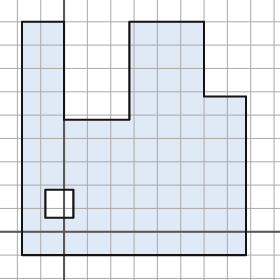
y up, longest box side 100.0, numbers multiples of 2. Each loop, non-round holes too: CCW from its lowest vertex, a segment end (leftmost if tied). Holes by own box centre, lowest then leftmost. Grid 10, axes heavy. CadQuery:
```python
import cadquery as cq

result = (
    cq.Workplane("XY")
    .moveTo(-18.0, -10.0)
    .lineTo(78.0, -10.0)
    .lineTo(78.0, 58.0)
    .lineTo(60.0, 58.0)
    .lineTo(60.0, 90.0)
    .lineTo(28.0, 90.0)
    .lineTo(28.0, 48.0)
    .lineTo(0.0, 48.0)
    .lineTo(0.0, 90.0)
    .lineTo(-18.0, 90.0)
    .close()
    .moveTo(-8.0, 6.0)
    .lineTo(4.0, 6.0)
    .lineTo(4.0, 18.0)
    .lineTo(-8.0, 18.0)
    .close()
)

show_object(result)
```